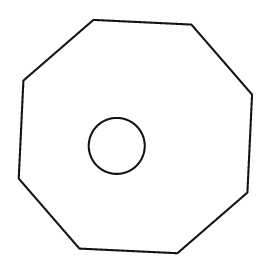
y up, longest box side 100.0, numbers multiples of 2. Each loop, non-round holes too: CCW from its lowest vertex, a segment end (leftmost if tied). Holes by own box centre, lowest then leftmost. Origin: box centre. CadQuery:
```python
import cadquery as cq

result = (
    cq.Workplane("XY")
    .moveTo(18.0, -50.0)
    .lineTo(48.0, -24.0)
    .lineTo(50.0, 18.0)
    .lineTo(24.0, 48.0)
    .lineTo(-18.0, 50.0)
    .lineTo(-48.0, 24.0)
    .lineTo(-50.0, -18.0)
    .lineTo(-24.0, -48.0)
    .close()
    .moveTo(-8.0, -4.0)
    .circle(12.0)
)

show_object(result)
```